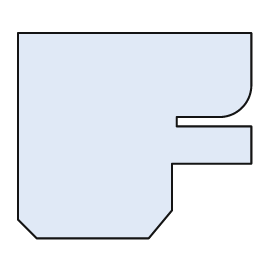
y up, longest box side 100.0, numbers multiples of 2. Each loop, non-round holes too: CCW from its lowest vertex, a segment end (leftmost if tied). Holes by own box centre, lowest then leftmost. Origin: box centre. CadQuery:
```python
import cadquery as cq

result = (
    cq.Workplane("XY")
    .moveTo(-42.0, -44.0)
    .lineTo(6.0, -44.0)
    .lineTo(16.0, -32.0)
    .lineTo(16.0, -12.0)
    .lineTo(50.0, -12.0)
    .lineTo(50.0, 4.0)
    .lineTo(18.0, 4.0)
    .lineTo(18.0, 8.0)
    .lineTo(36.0, 8.0)
    .threePointArc((46.0, 12.0), (50.0, 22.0))
    .lineTo(50.0, 44.0)
    .lineTo(-50.0, 44.0)
    .lineTo(-50.0, -36.0)
    .close()
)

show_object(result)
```